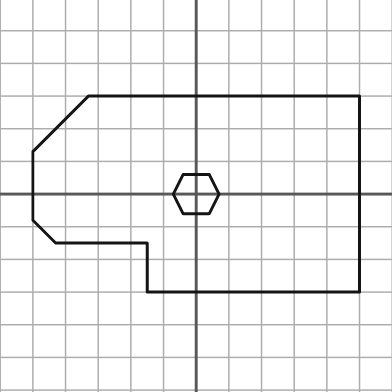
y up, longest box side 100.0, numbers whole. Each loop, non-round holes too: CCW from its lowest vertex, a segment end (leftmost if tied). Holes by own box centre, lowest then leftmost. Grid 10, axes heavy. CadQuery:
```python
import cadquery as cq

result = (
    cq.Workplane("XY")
    .moveTo(-15.0, -30.0)
    .lineTo(50.0, -30.0)
    .lineTo(50.0, 30.0)
    .lineTo(-33.0, 30.0)
    .lineTo(-50.0, 13.0)
    .lineTo(-50.0, -8.0)
    .lineTo(-43.0, -15.0)
    .lineTo(-15.0, -15.0)
    .close()
    .moveTo(-4.0, -6.0)
    .lineTo(4.0, -6.0)
    .lineTo(7.0, 0.0)
    .lineTo(4.0, 6.0)
    .lineTo(-4.0, 6.0)
    .lineTo(-7.0, 0.0)
    .close()
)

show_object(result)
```